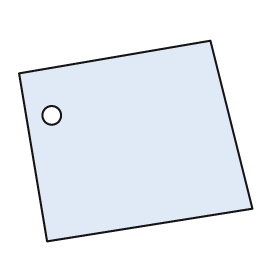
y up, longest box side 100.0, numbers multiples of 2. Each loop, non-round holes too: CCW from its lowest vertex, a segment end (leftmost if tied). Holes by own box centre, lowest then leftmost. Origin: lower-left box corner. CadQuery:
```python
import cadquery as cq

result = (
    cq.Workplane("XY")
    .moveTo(12.0, 0.0)
    .lineTo(100.0, 14.0)
    .lineTo(82.0, 86.0)
    .lineTo(0.0, 72.0)
    .close()
    .moveTo(14.0, 54.0)
    .circle(4.0)
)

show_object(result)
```